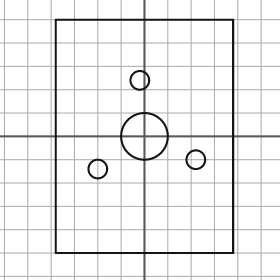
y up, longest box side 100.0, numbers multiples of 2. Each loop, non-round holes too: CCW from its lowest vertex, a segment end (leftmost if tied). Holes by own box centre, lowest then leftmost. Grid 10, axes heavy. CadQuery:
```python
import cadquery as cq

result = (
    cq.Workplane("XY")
    .moveTo(-38.0, -50.0)
    .lineTo(38.0, -50.0)
    .lineTo(38.0, 50.0)
    .lineTo(-38.0, 50.0)
    .close()
    .moveTo(-20.0, -14.0)
    .circle(4.0)
    .moveTo(22.0, -10.0)
    .circle(4.0)
    .moveTo(0.0, 0.0)
    .circle(10.0)
    .moveTo(-2.0, 24.0)
    .circle(4.0)
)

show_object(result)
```